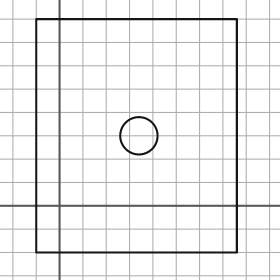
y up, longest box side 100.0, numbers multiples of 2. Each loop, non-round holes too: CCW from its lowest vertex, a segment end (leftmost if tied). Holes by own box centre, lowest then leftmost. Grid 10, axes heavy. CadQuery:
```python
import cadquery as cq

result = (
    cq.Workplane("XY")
    .moveTo(-10.0, -20.0)
    .lineTo(76.0, -20.0)
    .lineTo(76.0, 80.0)
    .lineTo(-10.0, 80.0)
    .close()
    .moveTo(34.0, 30.0)
    .circle(8.0)
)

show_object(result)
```